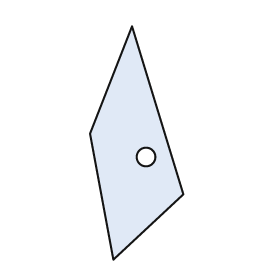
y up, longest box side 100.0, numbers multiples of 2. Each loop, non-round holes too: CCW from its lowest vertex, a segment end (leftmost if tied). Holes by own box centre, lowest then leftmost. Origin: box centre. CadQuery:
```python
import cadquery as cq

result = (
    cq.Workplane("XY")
    .moveTo(-10.0, -50.0)
    .lineTo(20.0, -22.0)
    .lineTo(-2.0, 50.0)
    .lineTo(-20.0, 4.0)
    .close()
    .moveTo(4.0, -6.0)
    .circle(4.0)
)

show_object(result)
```